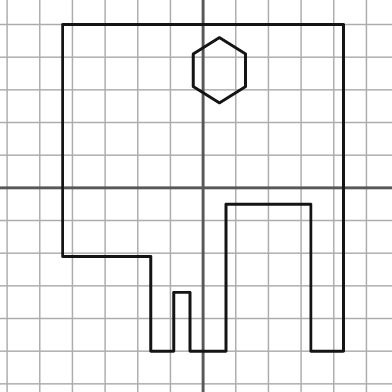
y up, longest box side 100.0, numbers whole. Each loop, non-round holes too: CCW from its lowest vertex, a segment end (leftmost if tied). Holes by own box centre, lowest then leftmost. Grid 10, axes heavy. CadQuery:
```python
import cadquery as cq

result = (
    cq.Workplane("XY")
    .moveTo(-16.0, -50.0)
    .lineTo(-9.0, -50.0)
    .lineTo(-9.0, -32.0)
    .lineTo(-4.0, -32.0)
    .lineTo(-4.0, -50.0)
    .lineTo(7.0, -50.0)
    .lineTo(7.0, -5.0)
    .lineTo(33.0, -5.0)
    .lineTo(33.0, -50.0)
    .lineTo(43.0, -50.0)
    .lineTo(43.0, 50.0)
    .lineTo(-43.0, 50.0)
    .lineTo(-43.0, -21.0)
    .lineTo(-16.0, -21.0)
    .close()
    .moveTo(5.0, 26.0)
    .lineTo(13.0, 31.0)
    .lineTo(13.0, 41.0)
    .lineTo(5.0, 46.0)
    .lineTo(-3.0, 41.0)
    .lineTo(-3.0, 31.0)
    .close()
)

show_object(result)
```